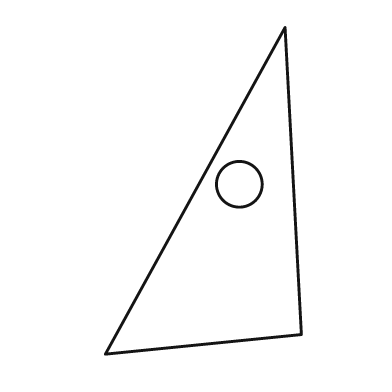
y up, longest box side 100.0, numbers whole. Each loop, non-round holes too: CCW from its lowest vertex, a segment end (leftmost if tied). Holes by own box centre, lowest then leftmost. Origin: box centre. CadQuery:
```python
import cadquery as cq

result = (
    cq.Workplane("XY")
    .moveTo(-30.0, -50.0)
    .lineTo(30.0, -44.0)
    .lineTo(25.0, 50.0)
    .close()
    .moveTo(11.0, 2.0)
    .circle(7.0)
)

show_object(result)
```